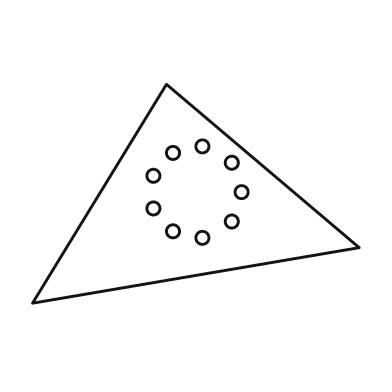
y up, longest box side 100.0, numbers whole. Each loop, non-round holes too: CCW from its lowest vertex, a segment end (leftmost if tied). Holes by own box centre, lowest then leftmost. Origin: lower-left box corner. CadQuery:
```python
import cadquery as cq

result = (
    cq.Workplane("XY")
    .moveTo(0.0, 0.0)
    .lineTo(100.0, 17.0)
    .lineTo(41.0, 67.0)
    .close()
    .moveTo(52.0, 20.0)
    .circle(2.0)
    .moveTo(43.0, 22.0)
    .circle(2.0)
    .moveTo(61.0, 25.0)
    .circle(2.0)
    .moveTo(37.0, 29.0)
    .circle(2.0)
    .moveTo(64.0, 34.0)
    .circle(2.0)
    .moveTo(37.0, 39.0)
    .circle(2.0)
    .moveTo(61.0, 43.0)
    .circle(2.0)
    .moveTo(43.0, 46.0)
    .circle(2.0)
    .moveTo(52.0, 48.0)
    .circle(2.0)
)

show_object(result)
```